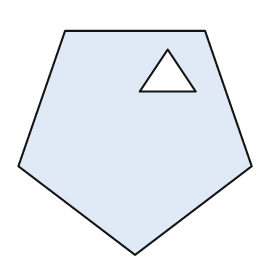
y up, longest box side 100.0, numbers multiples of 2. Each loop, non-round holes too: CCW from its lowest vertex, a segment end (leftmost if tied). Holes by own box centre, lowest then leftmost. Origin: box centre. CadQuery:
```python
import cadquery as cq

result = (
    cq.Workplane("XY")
    .moveTo(0.0, -48.0)
    .lineTo(50.0, -10.0)
    .lineTo(30.0, 48.0)
    .lineTo(-30.0, 48.0)
    .lineTo(-50.0, -10.0)
    .close()
    .moveTo(2.0, 22.0)
    .lineTo(26.0, 22.0)
    .lineTo(14.0, 40.0)
    .close()
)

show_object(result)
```